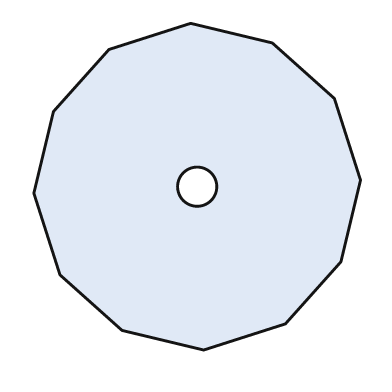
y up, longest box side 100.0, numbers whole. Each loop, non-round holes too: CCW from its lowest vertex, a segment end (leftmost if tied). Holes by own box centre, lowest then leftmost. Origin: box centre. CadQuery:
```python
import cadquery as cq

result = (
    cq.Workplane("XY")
    .moveTo(2.0, -50.0)
    .lineTo(27.0, -42.0)
    .lineTo(44.0, -23.0)
    .lineTo(50.0, 2.0)
    .lineTo(42.0, 27.0)
    .lineTo(23.0, 44.0)
    .lineTo(-2.0, 50.0)
    .lineTo(-27.0, 42.0)
    .lineTo(-44.0, 23.0)
    .lineTo(-50.0, -2.0)
    .lineTo(-42.0, -27.0)
    .lineTo(-23.0, -44.0)
    .close()
    .moveTo(0.0, 0.0)
    .circle(6.0)
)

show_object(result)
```